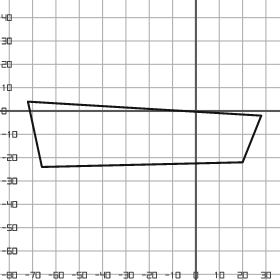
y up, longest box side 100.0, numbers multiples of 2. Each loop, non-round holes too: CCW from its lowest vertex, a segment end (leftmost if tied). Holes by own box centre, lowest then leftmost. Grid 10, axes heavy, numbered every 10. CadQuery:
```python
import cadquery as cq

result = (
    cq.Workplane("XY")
    .moveTo(-66.0, -24.0)
    .lineTo(20.0, -22.0)
    .lineTo(28.0, -2.0)
    .lineTo(-72.0, 4.0)
    .close()
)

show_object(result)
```